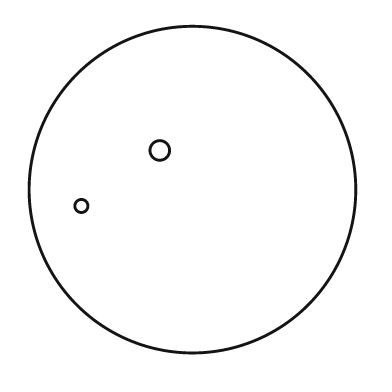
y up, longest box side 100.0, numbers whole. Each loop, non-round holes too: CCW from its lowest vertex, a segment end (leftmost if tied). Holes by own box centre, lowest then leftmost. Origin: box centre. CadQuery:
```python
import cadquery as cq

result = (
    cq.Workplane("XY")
    .moveTo(0.0, 0.0)
    .circle(50.0)
    .moveTo(-34.0, -5.0)
    .circle(2.0)
    .moveTo(-10.0, 12.0)
    .circle(3.0)
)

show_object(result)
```